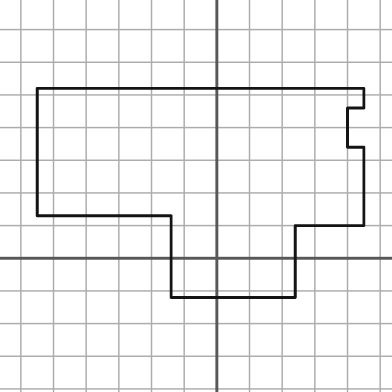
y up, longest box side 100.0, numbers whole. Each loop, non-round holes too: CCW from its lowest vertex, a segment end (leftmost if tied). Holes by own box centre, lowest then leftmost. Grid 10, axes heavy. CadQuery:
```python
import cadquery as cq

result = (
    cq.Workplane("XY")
    .moveTo(-14.0, -12.0)
    .lineTo(24.0, -12.0)
    .lineTo(24.0, 10.0)
    .lineTo(45.0, 10.0)
    .lineTo(45.0, 34.0)
    .lineTo(40.0, 34.0)
    .lineTo(40.0, 46.0)
    .lineTo(45.0, 46.0)
    .lineTo(45.0, 52.0)
    .lineTo(-55.0, 52.0)
    .lineTo(-55.0, 13.0)
    .lineTo(-14.0, 13.0)
    .close()
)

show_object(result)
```